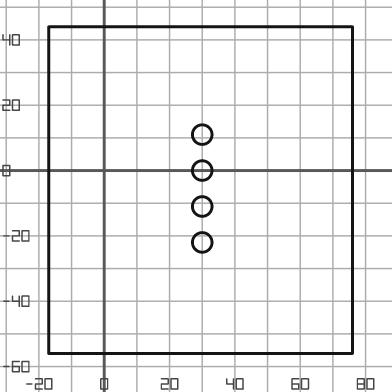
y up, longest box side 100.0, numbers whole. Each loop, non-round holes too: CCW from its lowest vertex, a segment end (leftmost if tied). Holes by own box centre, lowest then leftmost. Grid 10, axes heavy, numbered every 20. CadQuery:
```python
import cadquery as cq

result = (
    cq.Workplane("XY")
    .moveTo(-17.0, -56.0)
    .lineTo(76.0, -56.0)
    .lineTo(76.0, 44.0)
    .lineTo(-17.0, 44.0)
    .close()
    .moveTo(30.0, -22.0)
    .circle(3.0)
    .moveTo(30.0, -11.0)
    .circle(3.0)
    .moveTo(30.0, 0.0)
    .circle(3.0)
    .moveTo(30.0, 11.0)
    .circle(3.0)
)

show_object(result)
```